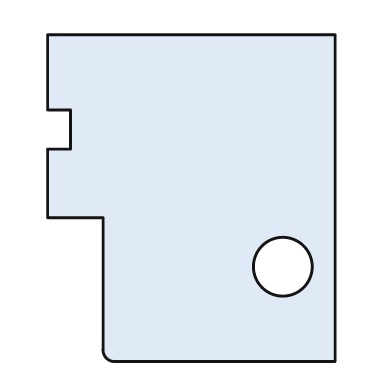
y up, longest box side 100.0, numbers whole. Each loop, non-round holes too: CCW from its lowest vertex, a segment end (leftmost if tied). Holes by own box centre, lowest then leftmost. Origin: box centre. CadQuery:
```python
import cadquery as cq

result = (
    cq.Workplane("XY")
    .moveTo(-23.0, -50.0)
    .lineTo(44.0, -50.0)
    .lineTo(44.0, 50.0)
    .lineTo(-44.0, 50.0)
    .lineTo(-44.0, 27.0)
    .lineTo(-37.0, 27.0)
    .lineTo(-37.0, 15.0)
    .lineTo(-44.0, 15.0)
    .lineTo(-44.0, -6.0)
    .lineTo(-27.0, -6.0)
    .lineTo(-27.0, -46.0)
    .threePointArc((-26.0, -49.0), (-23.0, -50.0))
    .close()
    .moveTo(28.0, -21.0)
    .circle(9.0)
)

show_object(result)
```